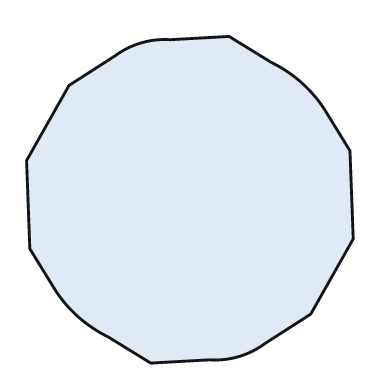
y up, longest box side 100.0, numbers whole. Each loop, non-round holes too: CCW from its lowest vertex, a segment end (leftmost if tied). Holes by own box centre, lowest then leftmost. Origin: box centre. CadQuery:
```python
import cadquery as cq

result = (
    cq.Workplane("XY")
    .moveTo(-12.0, -50.0)
    .lineTo(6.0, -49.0)
    .threePointArc((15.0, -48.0), (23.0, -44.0))
    .lineTo(37.0, -35.0)
    .lineTo(50.0, -12.0)
    .lineTo(49.0, 15.0)
    .lineTo(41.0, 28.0)
    .threePointArc((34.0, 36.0), (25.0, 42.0))
    .lineTo(12.0, 50.0)
    .lineTo(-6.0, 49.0)
    .threePointArc((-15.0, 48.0), (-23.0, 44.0))
    .lineTo(-37.0, 35.0)
    .lineTo(-50.0, 12.0)
    .lineTo(-49.0, -15.0)
    .lineTo(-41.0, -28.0)
    .threePointArc((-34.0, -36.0), (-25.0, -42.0))
    .close()
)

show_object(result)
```